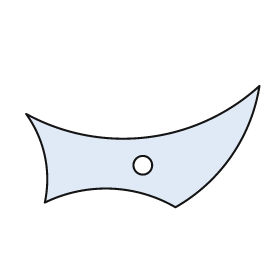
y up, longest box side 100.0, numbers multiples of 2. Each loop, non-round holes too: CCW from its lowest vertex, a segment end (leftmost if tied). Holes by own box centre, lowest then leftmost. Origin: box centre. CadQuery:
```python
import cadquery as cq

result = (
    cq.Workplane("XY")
    .moveTo(14.0, -26.0)
    .threePointArc((38.0, -4.0), (50.0, 26.0))
    .threePointArc((2.0, 4.0), (-50.0, 14.0))
    .threePointArc((-42.0, -4.0), (-42.0, -24.0))
    .threePointArc((-14.0, -18.0), (14.0, -26.0))
    .close()
    .moveTo(0.0, -8.0)
    .circle(4.0)
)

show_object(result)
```